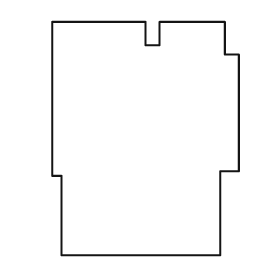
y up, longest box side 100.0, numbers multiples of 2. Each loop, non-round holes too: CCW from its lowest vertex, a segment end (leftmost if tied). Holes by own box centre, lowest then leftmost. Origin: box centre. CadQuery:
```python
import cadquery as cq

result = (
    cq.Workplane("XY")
    .moveTo(-36.0, -50.0)
    .lineTo(32.0, -50.0)
    .lineTo(32.0, -14.0)
    .lineTo(40.0, -14.0)
    .lineTo(40.0, 36.0)
    .lineTo(34.0, 36.0)
    .lineTo(34.0, 50.0)
    .lineTo(6.0, 50.0)
    .lineTo(6.0, 40.0)
    .lineTo(0.0, 40.0)
    .lineTo(0.0, 50.0)
    .lineTo(-40.0, 50.0)
    .lineTo(-40.0, -16.0)
    .lineTo(-36.0, -16.0)
    .close()
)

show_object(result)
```